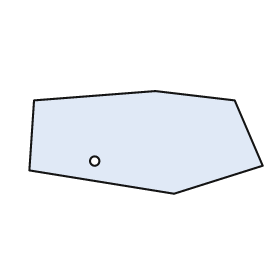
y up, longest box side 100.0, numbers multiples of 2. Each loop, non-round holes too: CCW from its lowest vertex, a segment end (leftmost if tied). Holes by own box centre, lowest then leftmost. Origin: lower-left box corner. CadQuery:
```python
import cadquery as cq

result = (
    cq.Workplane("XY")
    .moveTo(62.0, 0.0)
    .lineTo(100.0, 12.0)
    .lineTo(88.0, 40.0)
    .lineTo(54.0, 44.0)
    .lineTo(2.0, 40.0)
    .lineTo(0.0, 10.0)
    .close()
    .moveTo(28.0, 14.0)
    .circle(2.0)
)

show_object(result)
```